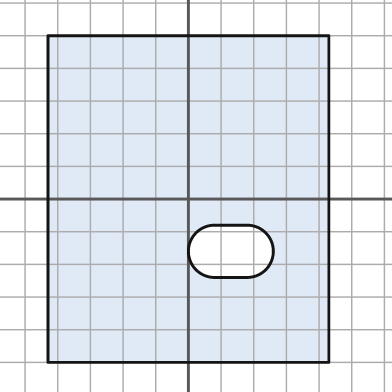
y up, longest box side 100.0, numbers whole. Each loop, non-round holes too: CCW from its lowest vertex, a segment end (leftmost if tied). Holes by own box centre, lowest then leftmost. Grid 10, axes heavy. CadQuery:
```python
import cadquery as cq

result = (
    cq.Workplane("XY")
    .moveTo(-43.0, -50.0)
    .lineTo(43.0, -50.0)
    .lineTo(43.0, 50.0)
    .lineTo(-43.0, 50.0)
    .close()
    .moveTo(8.0, -24.0)
    .lineTo(18.0, -24.0)
    .threePointArc((26.0, -16.0), (18.0, -8.0))
    .lineTo(8.0, -8.0)
    .threePointArc((0.0, -16.0), (8.0, -24.0))
    .close()
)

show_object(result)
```